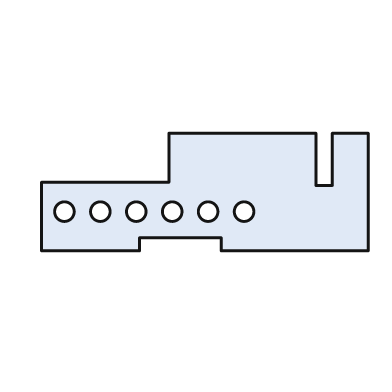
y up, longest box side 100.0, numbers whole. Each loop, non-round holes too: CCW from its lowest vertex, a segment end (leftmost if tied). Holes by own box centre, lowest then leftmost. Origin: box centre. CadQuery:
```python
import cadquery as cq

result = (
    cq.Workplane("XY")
    .moveTo(-50.0, -18.0)
    .lineTo(-20.0, -18.0)
    .lineTo(-20.0, -14.0)
    .lineTo(5.0, -14.0)
    .lineTo(5.0, -18.0)
    .lineTo(50.0, -18.0)
    .lineTo(50.0, 18.0)
    .lineTo(39.0, 18.0)
    .lineTo(39.0, 2.0)
    .lineTo(34.0, 2.0)
    .lineTo(34.0, 18.0)
    .lineTo(-11.0, 18.0)
    .lineTo(-11.0, 3.0)
    .lineTo(-50.0, 3.0)
    .close()
    .moveTo(-43.0, -6.0)
    .circle(3.0)
    .moveTo(-32.0, -6.0)
    .circle(3.0)
    .moveTo(-21.0, -6.0)
    .circle(3.0)
    .moveTo(-10.0, -6.0)
    .circle(3.0)
    .moveTo(1.0, -6.0)
    .circle(3.0)
    .moveTo(12.0, -6.0)
    .circle(3.0)
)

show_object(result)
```